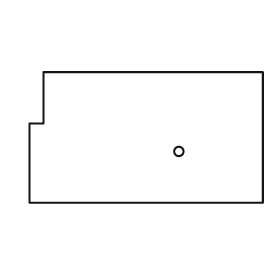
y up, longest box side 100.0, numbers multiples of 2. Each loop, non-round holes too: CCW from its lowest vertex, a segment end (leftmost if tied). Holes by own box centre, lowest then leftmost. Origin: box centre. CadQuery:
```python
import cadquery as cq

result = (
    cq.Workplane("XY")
    .moveTo(-50.0, -28.0)
    .lineTo(50.0, -28.0)
    .lineTo(50.0, 28.0)
    .lineTo(-44.0, 28.0)
    .lineTo(-44.0, 6.0)
    .lineTo(-50.0, 6.0)
    .close()
    .moveTo(14.0, -6.0)
    .circle(2.0)
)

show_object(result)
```